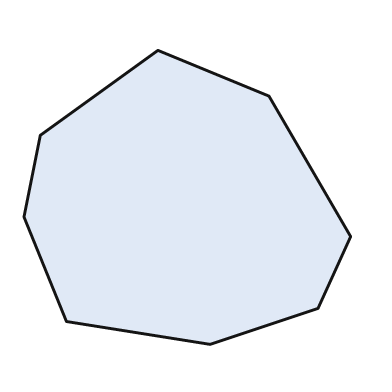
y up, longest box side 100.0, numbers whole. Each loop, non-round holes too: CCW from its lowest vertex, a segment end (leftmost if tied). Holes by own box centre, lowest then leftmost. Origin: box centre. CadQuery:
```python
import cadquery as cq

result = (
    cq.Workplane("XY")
    .moveTo(7.0, -45.0)
    .lineTo(40.0, -34.0)
    .lineTo(50.0, -12.0)
    .lineTo(25.0, 31.0)
    .lineTo(-9.0, 45.0)
    .lineTo(-45.0, 19.0)
    .lineTo(-50.0, -6.0)
    .lineTo(-37.0, -38.0)
    .close()
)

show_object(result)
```